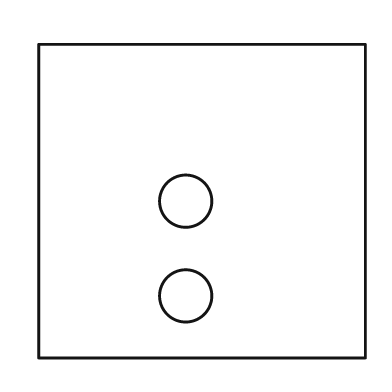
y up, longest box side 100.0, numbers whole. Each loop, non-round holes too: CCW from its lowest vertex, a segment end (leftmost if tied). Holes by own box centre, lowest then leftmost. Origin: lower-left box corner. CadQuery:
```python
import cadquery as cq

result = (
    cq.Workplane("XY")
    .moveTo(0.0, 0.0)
    .lineTo(100.0, 0.0)
    .lineTo(100.0, 96.0)
    .lineTo(0.0, 96.0)
    .close()
    .moveTo(45.0, 19.0)
    .circle(8.0)
    .moveTo(45.0, 48.0)
    .circle(8.0)
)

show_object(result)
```